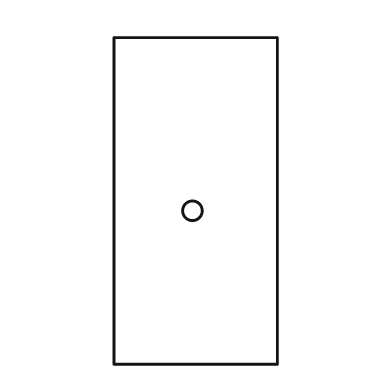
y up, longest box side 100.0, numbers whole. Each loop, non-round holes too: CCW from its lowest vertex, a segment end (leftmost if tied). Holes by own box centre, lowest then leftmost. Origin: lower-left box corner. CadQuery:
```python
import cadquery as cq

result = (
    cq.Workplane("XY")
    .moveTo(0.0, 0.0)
    .lineTo(50.0, 0.0)
    .lineTo(50.0, 100.0)
    .lineTo(0.0, 100.0)
    .close()
    .moveTo(24.0, 47.0)
    .circle(3.0)
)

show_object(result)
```